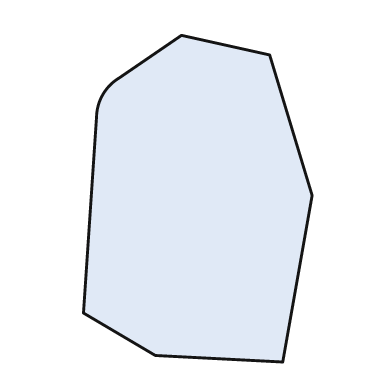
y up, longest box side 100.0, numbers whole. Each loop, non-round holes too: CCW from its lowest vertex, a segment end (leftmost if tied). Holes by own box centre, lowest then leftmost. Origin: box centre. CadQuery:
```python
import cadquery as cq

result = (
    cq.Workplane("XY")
    .moveTo(26.0, -50.0)
    .lineTo(35.0, 1.0)
    .lineTo(22.0, 44.0)
    .lineTo(-5.0, 50.0)
    .lineTo(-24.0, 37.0)
    .threePointArc((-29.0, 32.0), (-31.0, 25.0))
    .lineTo(-35.0, -35.0)
    .lineTo(-13.0, -48.0)
    .close()
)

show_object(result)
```